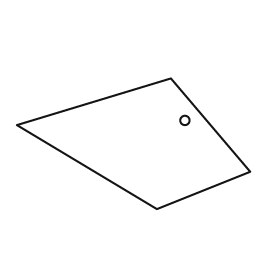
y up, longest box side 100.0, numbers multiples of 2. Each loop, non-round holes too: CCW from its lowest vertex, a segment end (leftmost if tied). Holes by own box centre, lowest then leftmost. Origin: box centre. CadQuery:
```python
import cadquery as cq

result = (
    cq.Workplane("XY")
    .moveTo(10.0, -28.0)
    .lineTo(50.0, -12.0)
    .lineTo(16.0, 28.0)
    .lineTo(-50.0, 8.0)
    .close()
    .moveTo(22.0, 10.0)
    .circle(2.0)
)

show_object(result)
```